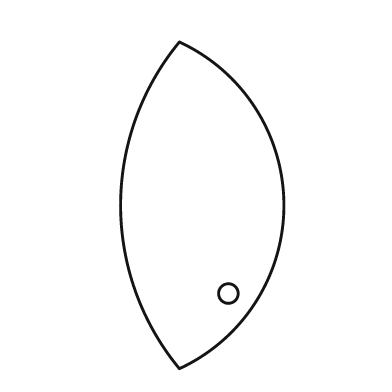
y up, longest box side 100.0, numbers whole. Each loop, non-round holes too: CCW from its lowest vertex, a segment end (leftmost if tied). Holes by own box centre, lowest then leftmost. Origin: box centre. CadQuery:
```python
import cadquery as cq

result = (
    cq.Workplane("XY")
    .moveTo(-7.0, -50.0)
    .threePointArc((25.0, 0.0), (-7.0, 50.0))
    .threePointArc((-25.0, 0.0), (-7.0, -50.0))
    .close()
    .moveTo(8.0, -27.0)
    .circle(3.0)
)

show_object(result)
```